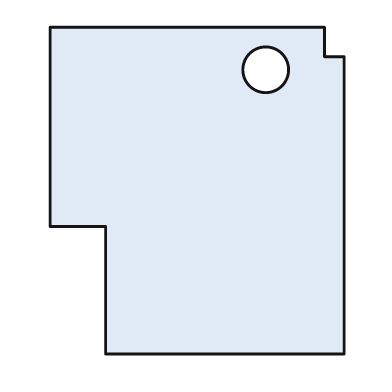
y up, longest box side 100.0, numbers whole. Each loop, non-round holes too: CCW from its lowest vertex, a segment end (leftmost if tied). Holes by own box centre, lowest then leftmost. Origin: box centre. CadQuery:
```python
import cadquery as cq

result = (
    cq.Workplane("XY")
    .moveTo(-28.0, -50.0)
    .lineTo(45.0, -50.0)
    .lineTo(45.0, 41.0)
    .lineTo(39.0, 41.0)
    .lineTo(39.0, 50.0)
    .lineTo(-45.0, 50.0)
    .lineTo(-45.0, -11.0)
    .lineTo(-28.0, -11.0)
    .close()
    .moveTo(21.0, 37.0)
    .circle(7.0)
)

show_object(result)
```